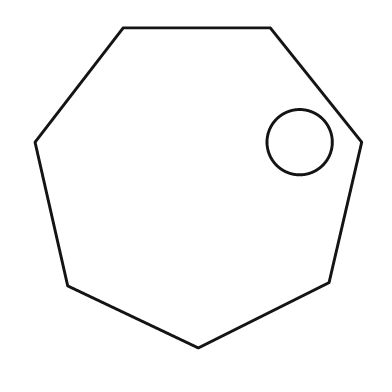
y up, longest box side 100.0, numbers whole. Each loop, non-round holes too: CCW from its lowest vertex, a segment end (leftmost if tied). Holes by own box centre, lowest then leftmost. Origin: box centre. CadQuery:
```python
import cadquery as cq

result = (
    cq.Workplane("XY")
    .moveTo(0.0, -49.0)
    .lineTo(40.0, -29.0)
    .lineTo(50.0, 14.0)
    .lineTo(22.0, 49.0)
    .lineTo(-23.0, 49.0)
    .lineTo(-50.0, 14.0)
    .lineTo(-40.0, -30.0)
    .close()
    .moveTo(31.0, 14.0)
    .circle(10.0)
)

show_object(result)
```